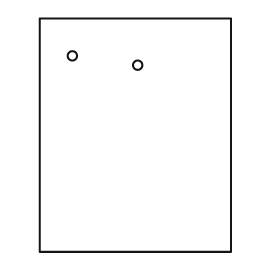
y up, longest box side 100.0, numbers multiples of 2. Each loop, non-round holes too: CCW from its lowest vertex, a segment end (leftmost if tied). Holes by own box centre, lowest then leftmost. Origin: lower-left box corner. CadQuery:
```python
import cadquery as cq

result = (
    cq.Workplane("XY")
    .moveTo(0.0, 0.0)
    .lineTo(82.0, 0.0)
    .lineTo(82.0, 100.0)
    .lineTo(0.0, 100.0)
    .close()
    .moveTo(42.0, 80.0)
    .circle(2.0)
    .moveTo(14.0, 84.0)
    .circle(2.0)
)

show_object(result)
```